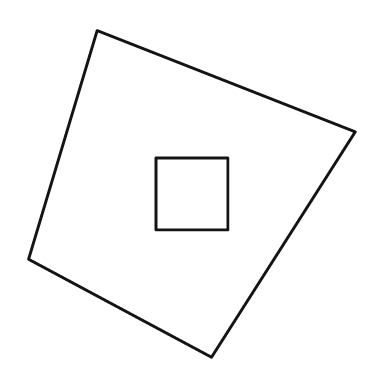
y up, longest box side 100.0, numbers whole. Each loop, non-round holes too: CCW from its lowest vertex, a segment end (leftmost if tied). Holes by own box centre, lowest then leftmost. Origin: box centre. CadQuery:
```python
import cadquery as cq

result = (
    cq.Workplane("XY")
    .moveTo(6.0, -50.0)
    .lineTo(50.0, 19.0)
    .lineTo(-29.0, 50.0)
    .lineTo(-50.0, -20.0)
    .close()
    .moveTo(-11.0, -11.0)
    .lineTo(11.0, -11.0)
    .lineTo(11.0, 11.0)
    .lineTo(-11.0, 11.0)
    .close()
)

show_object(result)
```